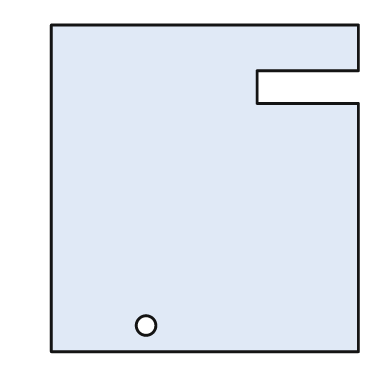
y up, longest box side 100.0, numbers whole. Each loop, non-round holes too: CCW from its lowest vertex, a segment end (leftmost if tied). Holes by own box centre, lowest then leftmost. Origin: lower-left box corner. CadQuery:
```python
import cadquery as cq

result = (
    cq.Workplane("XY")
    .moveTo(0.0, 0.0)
    .lineTo(94.0, 0.0)
    .lineTo(94.0, 76.0)
    .lineTo(63.0, 76.0)
    .lineTo(63.0, 86.0)
    .lineTo(94.0, 86.0)
    .lineTo(94.0, 100.0)
    .lineTo(0.0, 100.0)
    .close()
    .moveTo(29.0, 8.0)
    .circle(3.0)
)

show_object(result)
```